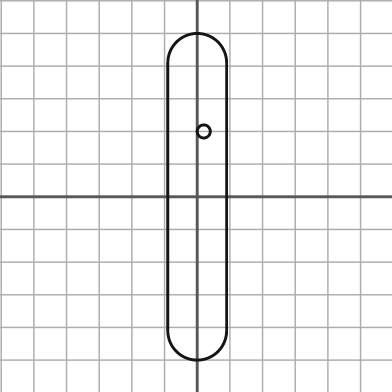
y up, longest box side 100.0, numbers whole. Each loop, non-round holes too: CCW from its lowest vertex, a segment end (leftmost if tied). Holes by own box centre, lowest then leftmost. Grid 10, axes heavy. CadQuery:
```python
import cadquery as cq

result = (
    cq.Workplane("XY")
    .moveTo(-9.0, -41.0)
    .threePointArc((0.0, -50.0), (9.0, -41.0))
    .lineTo(9.0, 41.0)
    .threePointArc((0.0, 50.0), (-9.0, 41.0))
    .close()
    .moveTo(2.0, 20.0)
    .circle(2.0)
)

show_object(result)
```